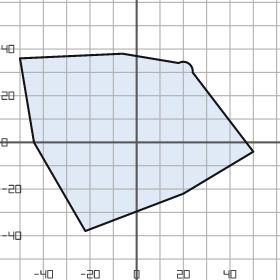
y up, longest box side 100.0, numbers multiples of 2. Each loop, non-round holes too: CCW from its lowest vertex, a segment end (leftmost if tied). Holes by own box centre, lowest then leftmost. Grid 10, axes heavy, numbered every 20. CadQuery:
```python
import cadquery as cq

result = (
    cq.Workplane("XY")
    .moveTo(-22.0, -38.0)
    .lineTo(20.0, -22.0)
    .lineTo(50.0, -4.0)
    .lineTo(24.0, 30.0)
    .threePointArc((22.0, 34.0), (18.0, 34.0))
    .lineTo(-6.0, 38.0)
    .lineTo(-50.0, 36.0)
    .lineTo(-44.0, 0.0)
    .close()
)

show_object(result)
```